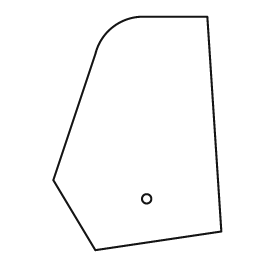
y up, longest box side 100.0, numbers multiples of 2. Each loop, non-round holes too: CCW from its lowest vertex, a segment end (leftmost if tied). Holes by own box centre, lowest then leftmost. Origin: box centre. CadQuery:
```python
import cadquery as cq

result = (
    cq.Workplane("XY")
    .moveTo(-18.0, -50.0)
    .lineTo(36.0, -42.0)
    .lineTo(30.0, 50.0)
    .lineTo(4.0, 50.0)
    .threePointArc((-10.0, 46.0), (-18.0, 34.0))
    .lineTo(-36.0, -20.0)
    .close()
    .moveTo(4.0, -28.0)
    .circle(2.0)
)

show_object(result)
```